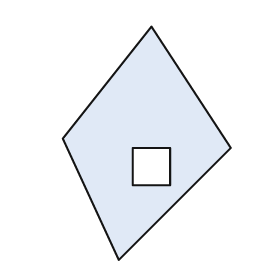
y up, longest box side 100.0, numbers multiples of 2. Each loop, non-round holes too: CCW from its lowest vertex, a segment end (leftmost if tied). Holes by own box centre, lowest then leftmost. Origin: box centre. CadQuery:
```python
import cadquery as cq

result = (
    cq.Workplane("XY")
    .moveTo(-12.0, -50.0)
    .lineTo(36.0, -2.0)
    .lineTo(2.0, 50.0)
    .lineTo(-36.0, 2.0)
    .close()
    .moveTo(-6.0, -18.0)
    .lineTo(10.0, -18.0)
    .lineTo(10.0, -2.0)
    .lineTo(-6.0, -2.0)
    .close()
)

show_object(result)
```